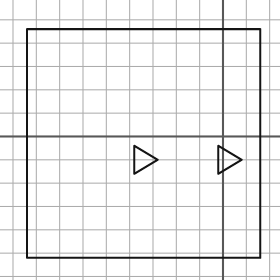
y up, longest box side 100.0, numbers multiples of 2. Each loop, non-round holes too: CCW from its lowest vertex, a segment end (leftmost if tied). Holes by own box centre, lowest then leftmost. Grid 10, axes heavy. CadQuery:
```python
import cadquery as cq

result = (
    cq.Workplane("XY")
    .moveTo(-84.0, -52.0)
    .lineTo(16.0, -52.0)
    .lineTo(16.0, 46.0)
    .lineTo(-84.0, 46.0)
    .close()
    .moveTo(-38.0, -16.0)
    .lineTo(-28.0, -10.0)
    .lineTo(-38.0, -4.0)
    .close()
    .moveTo(-2.0, -16.0)
    .lineTo(8.0, -10.0)
    .lineTo(-2.0, -4.0)
    .close()
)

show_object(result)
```